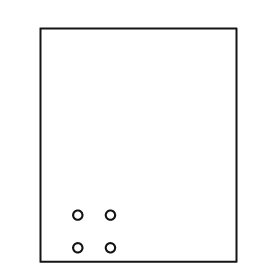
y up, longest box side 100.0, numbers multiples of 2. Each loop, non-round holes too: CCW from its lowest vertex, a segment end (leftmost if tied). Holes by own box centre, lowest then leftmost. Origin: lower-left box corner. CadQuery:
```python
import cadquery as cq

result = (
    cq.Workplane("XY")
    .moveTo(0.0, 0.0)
    .lineTo(84.0, 0.0)
    .lineTo(84.0, 100.0)
    .lineTo(0.0, 100.0)
    .close()
    .moveTo(16.0, 6.0)
    .circle(2.0)
    .moveTo(30.0, 6.0)
    .circle(2.0)
    .moveTo(16.0, 20.0)
    .circle(2.0)
    .moveTo(30.0, 20.0)
    .circle(2.0)
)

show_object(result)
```